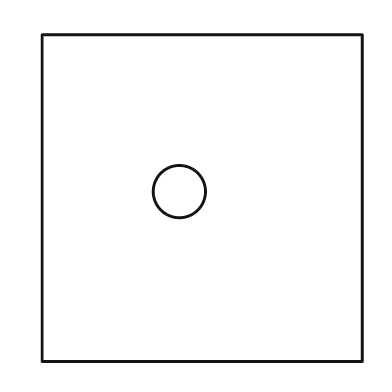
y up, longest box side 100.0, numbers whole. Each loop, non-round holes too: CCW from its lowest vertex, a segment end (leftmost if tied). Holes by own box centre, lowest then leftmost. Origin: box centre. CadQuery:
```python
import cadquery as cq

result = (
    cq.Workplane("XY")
    .moveTo(-49.0, -50.0)
    .lineTo(49.0, -50.0)
    .lineTo(49.0, 50.0)
    .lineTo(-49.0, 50.0)
    .close()
    .moveTo(-7.0, 2.0)
    .circle(8.0)
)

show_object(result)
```